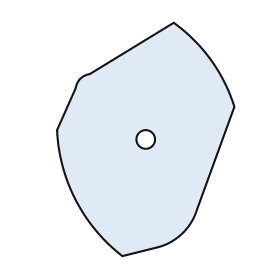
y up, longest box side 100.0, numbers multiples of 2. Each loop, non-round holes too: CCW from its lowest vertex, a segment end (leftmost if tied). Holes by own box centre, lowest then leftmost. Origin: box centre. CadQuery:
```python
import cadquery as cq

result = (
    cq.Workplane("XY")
    .moveTo(-10.0, -50.0)
    .lineTo(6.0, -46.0)
    .threePointArc((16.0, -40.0), (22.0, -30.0))
    .lineTo(38.0, 14.0)
    .threePointArc((28.0, 34.0), (12.0, 50.0))
    .lineTo(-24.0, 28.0)
    .threePointArc((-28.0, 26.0), (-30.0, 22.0))
    .lineTo(-38.0, 4.0)
    .threePointArc((-30.0, -26.0), (-10.0, -50.0))
    .close()
    .moveTo(0.0, 0.0)
    .circle(4.0)
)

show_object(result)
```